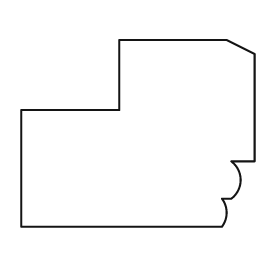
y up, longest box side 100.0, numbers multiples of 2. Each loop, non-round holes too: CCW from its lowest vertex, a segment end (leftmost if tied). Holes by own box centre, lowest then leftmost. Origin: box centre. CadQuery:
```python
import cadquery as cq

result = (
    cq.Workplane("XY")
    .moveTo(-50.0, -40.0)
    .lineTo(36.0, -40.0)
    .threePointArc((38.0, -34.0), (36.0, -28.0))
    .lineTo(40.0, -28.0)
    .threePointArc((44.0, -20.0), (40.0, -12.0))
    .lineTo(50.0, -12.0)
    .lineTo(50.0, 34.0)
    .lineTo(38.0, 40.0)
    .lineTo(-8.0, 40.0)
    .lineTo(-8.0, 10.0)
    .lineTo(-50.0, 10.0)
    .close()
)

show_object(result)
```